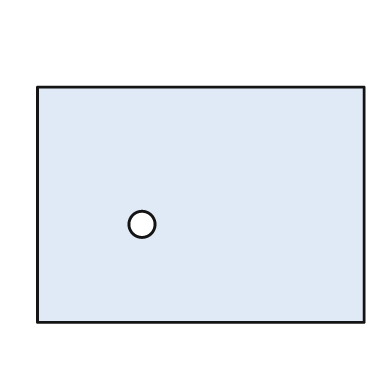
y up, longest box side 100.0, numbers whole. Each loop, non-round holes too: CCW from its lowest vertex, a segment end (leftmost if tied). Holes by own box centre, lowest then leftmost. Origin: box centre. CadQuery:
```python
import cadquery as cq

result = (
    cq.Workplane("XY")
    .moveTo(-50.0, -36.0)
    .lineTo(50.0, -36.0)
    .lineTo(50.0, 36.0)
    .lineTo(-50.0, 36.0)
    .close()
    .moveTo(-18.0, -6.0)
    .circle(4.0)
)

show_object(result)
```